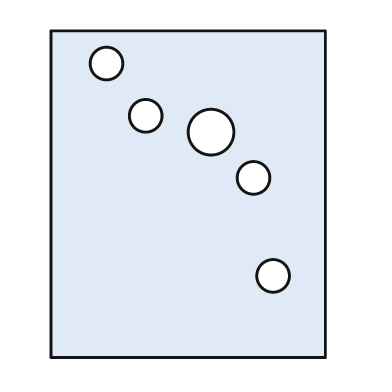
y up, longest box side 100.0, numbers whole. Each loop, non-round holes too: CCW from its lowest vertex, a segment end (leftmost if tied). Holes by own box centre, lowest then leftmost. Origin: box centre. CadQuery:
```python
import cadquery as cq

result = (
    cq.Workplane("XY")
    .moveTo(-42.0, -50.0)
    .lineTo(42.0, -50.0)
    .lineTo(42.0, 50.0)
    .lineTo(-42.0, 50.0)
    .close()
    .moveTo(26.0, -25.0)
    .circle(5.0)
    .moveTo(20.0, 5.0)
    .circle(5.0)
    .moveTo(7.0, 19.0)
    .circle(7.0)
    .moveTo(-13.0, 24.0)
    .circle(5.0)
    .moveTo(-25.0, 40.0)
    .circle(5.0)
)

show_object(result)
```